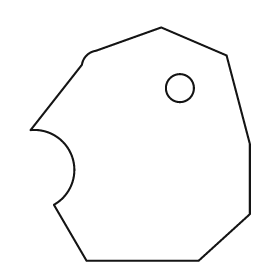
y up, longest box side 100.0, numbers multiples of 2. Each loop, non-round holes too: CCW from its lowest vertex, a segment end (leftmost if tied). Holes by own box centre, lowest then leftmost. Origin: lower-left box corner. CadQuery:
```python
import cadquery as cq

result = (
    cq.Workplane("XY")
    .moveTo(24.0, 0.0)
    .lineTo(72.0, 0.0)
    .lineTo(94.0, 20.0)
    .lineTo(94.0, 50.0)
    .lineTo(84.0, 88.0)
    .lineTo(56.0, 100.0)
    .lineTo(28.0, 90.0)
    .threePointArc((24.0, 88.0), (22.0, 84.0))
    .lineTo(0.0, 56.0)
    .threePointArc((18.0, 44.0), (10.0, 24.0))
    .close()
    .moveTo(64.0, 74.0)
    .circle(6.0)
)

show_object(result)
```